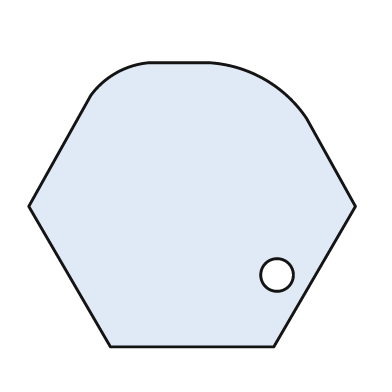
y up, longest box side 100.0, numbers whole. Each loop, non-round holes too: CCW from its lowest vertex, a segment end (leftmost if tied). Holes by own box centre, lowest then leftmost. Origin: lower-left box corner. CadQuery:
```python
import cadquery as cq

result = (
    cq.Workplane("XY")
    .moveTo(25.0, 0.0)
    .lineTo(75.0, 0.0)
    .lineTo(100.0, 43.0)
    .lineTo(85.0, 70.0)
    .threePointArc((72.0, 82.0), (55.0, 87.0))
    .lineTo(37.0, 87.0)
    .threePointArc((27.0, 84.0), (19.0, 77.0))
    .lineTo(0.0, 43.0)
    .close()
    .moveTo(76.0, 22.0)
    .circle(5.0)
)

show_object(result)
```